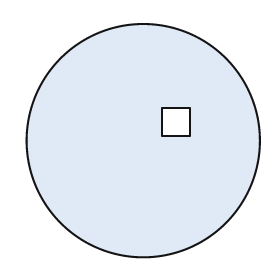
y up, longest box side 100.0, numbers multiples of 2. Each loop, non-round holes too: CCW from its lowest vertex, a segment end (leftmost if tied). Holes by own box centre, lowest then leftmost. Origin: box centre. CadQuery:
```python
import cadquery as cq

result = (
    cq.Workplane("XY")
    .moveTo(0.0, 0.0)
    .circle(50.0)
    .moveTo(8.0, 2.0)
    .lineTo(20.0, 2.0)
    .lineTo(20.0, 14.0)
    .lineTo(8.0, 14.0)
    .close()
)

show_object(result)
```